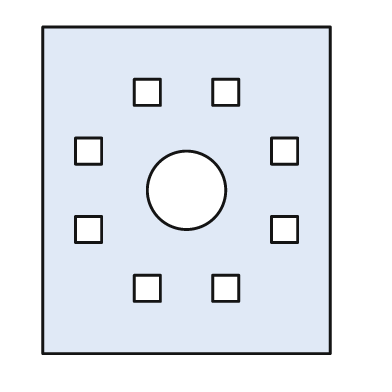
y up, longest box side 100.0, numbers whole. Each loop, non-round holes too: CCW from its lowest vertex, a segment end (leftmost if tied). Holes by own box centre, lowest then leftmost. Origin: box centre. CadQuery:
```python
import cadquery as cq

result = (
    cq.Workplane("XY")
    .moveTo(-44.0, -50.0)
    .lineTo(44.0, -50.0)
    .lineTo(44.0, 50.0)
    .lineTo(-44.0, 50.0)
    .close()
    .moveTo(-16.0, -34.0)
    .lineTo(-8.0, -34.0)
    .lineTo(-8.0, -26.0)
    .lineTo(-16.0, -26.0)
    .close()
    .moveTo(8.0, -34.0)
    .lineTo(16.0, -34.0)
    .lineTo(16.0, -26.0)
    .lineTo(8.0, -26.0)
    .close()
    .moveTo(-34.0, -16.0)
    .lineTo(-26.0, -16.0)
    .lineTo(-26.0, -8.0)
    .lineTo(-34.0, -8.0)
    .close()
    .moveTo(26.0, -16.0)
    .lineTo(34.0, -16.0)
    .lineTo(34.0, -8.0)
    .lineTo(26.0, -8.0)
    .close()
    .moveTo(0.0, 0.0)
    .circle(12.0)
    .moveTo(-34.0, 8.0)
    .lineTo(-26.0, 8.0)
    .lineTo(-26.0, 16.0)
    .lineTo(-34.0, 16.0)
    .close()
    .moveTo(26.0, 8.0)
    .lineTo(34.0, 8.0)
    .lineTo(34.0, 16.0)
    .lineTo(26.0, 16.0)
    .close()
    .moveTo(-16.0, 26.0)
    .lineTo(-8.0, 26.0)
    .lineTo(-8.0, 34.0)
    .lineTo(-16.0, 34.0)
    .close()
    .moveTo(8.0, 26.0)
    .lineTo(16.0, 26.0)
    .lineTo(16.0, 34.0)
    .lineTo(8.0, 34.0)
    .close()
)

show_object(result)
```